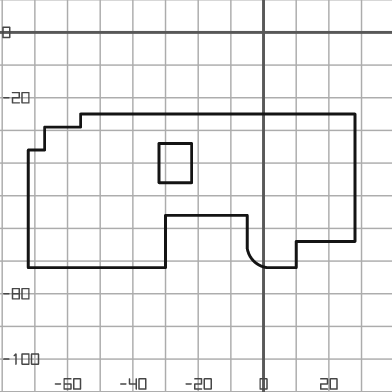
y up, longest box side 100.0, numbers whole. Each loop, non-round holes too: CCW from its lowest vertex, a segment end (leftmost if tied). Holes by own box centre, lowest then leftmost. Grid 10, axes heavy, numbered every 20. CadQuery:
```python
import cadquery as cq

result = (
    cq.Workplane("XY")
    .moveTo(-72.0, -72.0)
    .lineTo(-30.0, -72.0)
    .lineTo(-30.0, -56.0)
    .lineTo(-5.0, -56.0)
    .lineTo(-5.0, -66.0)
    .threePointArc((-3.0, -70.0), (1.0, -72.0))
    .lineTo(10.0, -72.0)
    .lineTo(10.0, -64.0)
    .lineTo(28.0, -64.0)
    .lineTo(28.0, -25.0)
    .lineTo(-56.0, -25.0)
    .lineTo(-56.0, -29.0)
    .lineTo(-67.0, -29.0)
    .lineTo(-67.0, -36.0)
    .lineTo(-72.0, -36.0)
    .close()
    .moveTo(-32.0, -46.0)
    .lineTo(-22.0, -46.0)
    .lineTo(-22.0, -34.0)
    .lineTo(-32.0, -34.0)
    .close()
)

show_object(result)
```